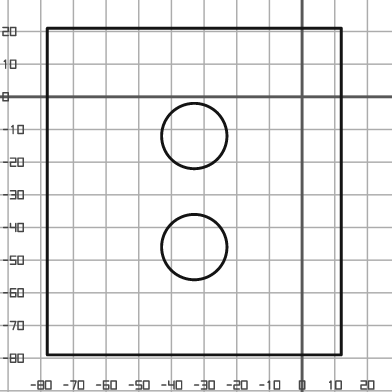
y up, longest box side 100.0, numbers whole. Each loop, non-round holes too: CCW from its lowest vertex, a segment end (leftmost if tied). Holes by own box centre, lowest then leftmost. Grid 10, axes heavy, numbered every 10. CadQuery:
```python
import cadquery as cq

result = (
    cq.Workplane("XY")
    .moveTo(-78.0, -79.0)
    .lineTo(12.0, -79.0)
    .lineTo(12.0, 21.0)
    .lineTo(-78.0, 21.0)
    .close()
    .moveTo(-33.0, -46.0)
    .circle(10.0)
    .moveTo(-33.0, -12.0)
    .circle(10.0)
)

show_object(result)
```